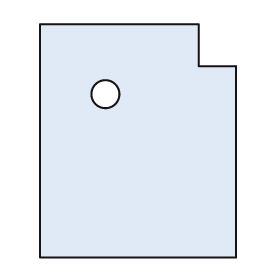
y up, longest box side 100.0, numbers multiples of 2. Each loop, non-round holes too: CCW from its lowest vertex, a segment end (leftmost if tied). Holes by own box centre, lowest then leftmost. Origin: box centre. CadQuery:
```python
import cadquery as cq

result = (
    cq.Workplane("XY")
    .moveTo(-42.0, -50.0)
    .lineTo(42.0, -50.0)
    .lineTo(42.0, 32.0)
    .lineTo(26.0, 32.0)
    .lineTo(26.0, 50.0)
    .lineTo(-42.0, 50.0)
    .close()
    .moveTo(-14.0, 20.0)
    .circle(6.0)
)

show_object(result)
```